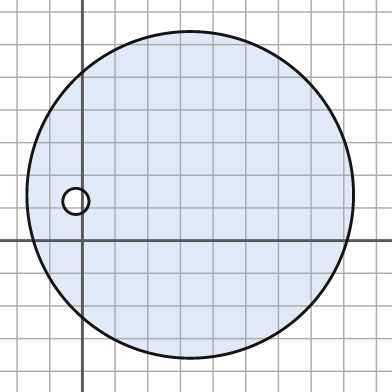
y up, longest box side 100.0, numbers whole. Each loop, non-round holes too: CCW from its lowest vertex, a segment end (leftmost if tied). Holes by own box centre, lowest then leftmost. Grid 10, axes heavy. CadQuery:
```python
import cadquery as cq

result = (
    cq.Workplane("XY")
    .moveTo(33.0, 14.0)
    .circle(50.0)
    .moveTo(-2.0, 12.0)
    .circle(4.0)
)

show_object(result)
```